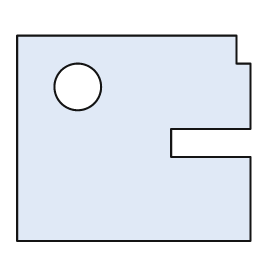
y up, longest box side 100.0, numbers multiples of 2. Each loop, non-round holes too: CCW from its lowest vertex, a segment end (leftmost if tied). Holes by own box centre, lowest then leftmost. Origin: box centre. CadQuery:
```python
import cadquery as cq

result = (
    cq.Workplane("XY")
    .moveTo(-50.0, -44.0)
    .lineTo(50.0, -44.0)
    .lineTo(50.0, -8.0)
    .lineTo(16.0, -8.0)
    .lineTo(16.0, 4.0)
    .lineTo(50.0, 4.0)
    .lineTo(50.0, 32.0)
    .lineTo(44.0, 32.0)
    .lineTo(44.0, 44.0)
    .lineTo(-50.0, 44.0)
    .close()
    .moveTo(-24.0, 22.0)
    .circle(10.0)
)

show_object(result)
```